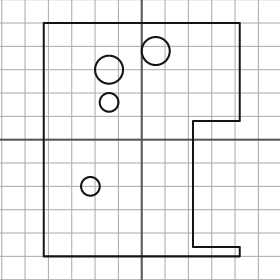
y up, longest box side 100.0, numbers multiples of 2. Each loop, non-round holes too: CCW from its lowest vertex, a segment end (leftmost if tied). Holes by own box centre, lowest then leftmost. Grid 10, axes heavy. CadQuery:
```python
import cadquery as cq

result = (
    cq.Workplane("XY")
    .moveTo(-42.0, -50.0)
    .lineTo(42.0, -50.0)
    .lineTo(42.0, -46.0)
    .lineTo(22.0, -46.0)
    .lineTo(22.0, 8.0)
    .lineTo(42.0, 8.0)
    .lineTo(42.0, 50.0)
    .lineTo(-42.0, 50.0)
    .close()
    .moveTo(-22.0, -20.0)
    .circle(4.0)
    .moveTo(-14.0, 16.0)
    .circle(4.0)
    .moveTo(-14.0, 30.0)
    .circle(6.0)
    .moveTo(6.0, 38.0)
    .circle(6.0)
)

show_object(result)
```